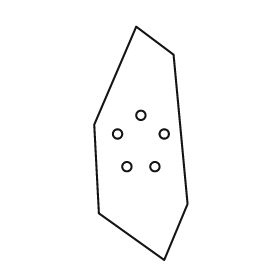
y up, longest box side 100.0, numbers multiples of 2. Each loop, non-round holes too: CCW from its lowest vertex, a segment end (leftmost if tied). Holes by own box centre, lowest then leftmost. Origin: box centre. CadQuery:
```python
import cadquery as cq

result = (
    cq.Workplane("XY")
    .moveTo(10.0, -50.0)
    .lineTo(20.0, -26.0)
    .lineTo(14.0, 38.0)
    .lineTo(-2.0, 50.0)
    .lineTo(-20.0, 8.0)
    .lineTo(-18.0, -30.0)
    .close()
    .moveTo(-6.0, -10.0)
    .circle(2.0)
    .moveTo(6.0, -10.0)
    .circle(2.0)
    .moveTo(-10.0, 4.0)
    .circle(2.0)
    .moveTo(10.0, 4.0)
    .circle(2.0)
    .moveTo(0.0, 12.0)
    .circle(2.0)
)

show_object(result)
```